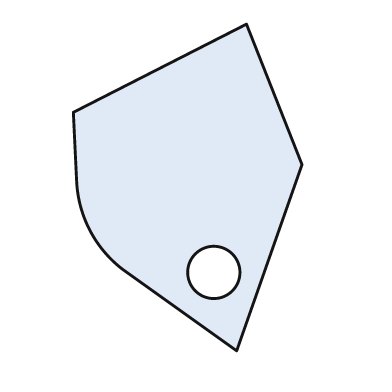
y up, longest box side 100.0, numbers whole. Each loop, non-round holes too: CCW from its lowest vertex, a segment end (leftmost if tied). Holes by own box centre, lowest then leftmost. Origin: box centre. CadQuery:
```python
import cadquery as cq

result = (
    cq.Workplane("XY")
    .moveTo(15.0, -50.0)
    .lineTo(35.0, 7.0)
    .lineTo(18.0, 50.0)
    .lineTo(-35.0, 23.0)
    .lineTo(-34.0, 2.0)
    .threePointArc((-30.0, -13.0), (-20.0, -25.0))
    .close()
    .moveTo(8.0, -26.0)
    .circle(8.0)
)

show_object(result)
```